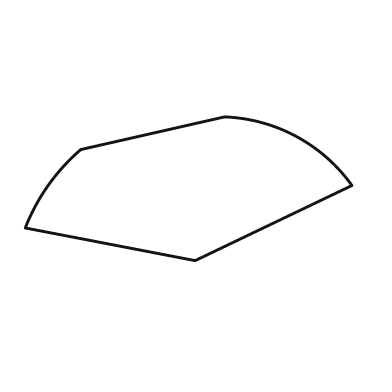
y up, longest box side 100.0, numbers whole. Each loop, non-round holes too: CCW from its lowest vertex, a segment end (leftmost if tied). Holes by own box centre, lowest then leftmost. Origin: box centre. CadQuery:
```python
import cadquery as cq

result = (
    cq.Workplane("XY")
    .moveTo(2.0, -22.0)
    .lineTo(50.0, 1.0)
    .threePointArc((33.0, 16.0), (11.0, 22.0))
    .lineTo(-33.0, 12.0)
    .threePointArc((-43.0, 1.0), (-50.0, -12.0))
    .close()
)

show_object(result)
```